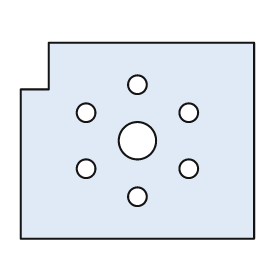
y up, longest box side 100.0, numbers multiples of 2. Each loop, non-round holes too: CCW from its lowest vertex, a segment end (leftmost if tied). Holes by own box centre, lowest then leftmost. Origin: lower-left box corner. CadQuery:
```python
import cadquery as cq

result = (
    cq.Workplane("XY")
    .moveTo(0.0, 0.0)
    .lineTo(100.0, 0.0)
    .lineTo(100.0, 84.0)
    .lineTo(12.0, 84.0)
    .lineTo(12.0, 64.0)
    .lineTo(0.0, 64.0)
    .close()
    .moveTo(50.0, 18.0)
    .circle(4.0)
    .moveTo(28.0, 30.0)
    .circle(4.0)
    .moveTo(72.0, 30.0)
    .circle(4.0)
    .moveTo(50.0, 42.0)
    .circle(8.0)
    .moveTo(28.0, 54.0)
    .circle(4.0)
    .moveTo(72.0, 54.0)
    .circle(4.0)
    .moveTo(50.0, 66.0)
    .circle(4.0)
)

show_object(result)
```